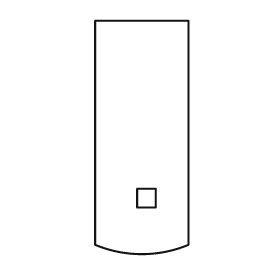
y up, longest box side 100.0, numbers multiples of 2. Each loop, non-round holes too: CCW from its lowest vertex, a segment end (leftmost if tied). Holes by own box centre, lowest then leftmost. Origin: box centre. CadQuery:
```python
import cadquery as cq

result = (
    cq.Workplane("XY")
    .moveTo(-20.0, -46.0)
    .threePointArc((0.0, -50.0), (20.0, -46.0))
    .lineTo(20.0, 50.0)
    .lineTo(-20.0, 50.0)
    .close()
    .moveTo(-2.0, -30.0)
    .lineTo(6.0, -30.0)
    .lineTo(6.0, -22.0)
    .lineTo(-2.0, -22.0)
    .close()
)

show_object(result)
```